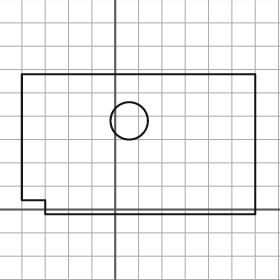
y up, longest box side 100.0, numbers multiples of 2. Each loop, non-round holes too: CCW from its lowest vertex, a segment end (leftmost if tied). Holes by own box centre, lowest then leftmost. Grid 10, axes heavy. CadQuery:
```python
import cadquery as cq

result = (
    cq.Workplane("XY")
    .moveTo(-30.0, -2.0)
    .lineTo(60.0, -2.0)
    .lineTo(60.0, 58.0)
    .lineTo(-40.0, 58.0)
    .lineTo(-40.0, 4.0)
    .lineTo(-30.0, 4.0)
    .close()
    .moveTo(6.0, 38.0)
    .circle(8.0)
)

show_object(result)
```